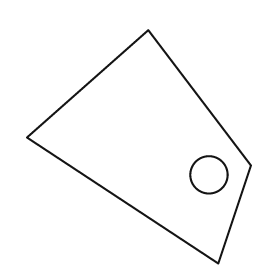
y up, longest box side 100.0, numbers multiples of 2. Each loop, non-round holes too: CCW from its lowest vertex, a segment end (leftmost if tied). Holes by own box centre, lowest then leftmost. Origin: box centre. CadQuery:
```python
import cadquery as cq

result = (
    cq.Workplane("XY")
    .moveTo(34.0, -50.0)
    .lineTo(48.0, -8.0)
    .lineTo(4.0, 50.0)
    .lineTo(-48.0, 4.0)
    .close()
    .moveTo(30.0, -12.0)
    .circle(8.0)
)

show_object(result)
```